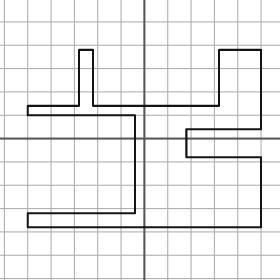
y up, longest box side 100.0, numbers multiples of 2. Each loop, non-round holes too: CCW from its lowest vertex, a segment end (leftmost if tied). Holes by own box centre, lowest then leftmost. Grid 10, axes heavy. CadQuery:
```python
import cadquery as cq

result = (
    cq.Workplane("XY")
    .moveTo(-50.0, -38.0)
    .lineTo(50.0, -38.0)
    .lineTo(50.0, -8.0)
    .lineTo(18.0, -8.0)
    .lineTo(18.0, 4.0)
    .lineTo(50.0, 4.0)
    .lineTo(50.0, 38.0)
    .lineTo(32.0, 38.0)
    .lineTo(32.0, 14.0)
    .lineTo(-22.0, 14.0)
    .lineTo(-22.0, 38.0)
    .lineTo(-28.0, 38.0)
    .lineTo(-28.0, 14.0)
    .lineTo(-50.0, 14.0)
    .lineTo(-50.0, 10.0)
    .lineTo(-4.0, 10.0)
    .lineTo(-4.0, -32.0)
    .lineTo(-50.0, -32.0)
    .close()
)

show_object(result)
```